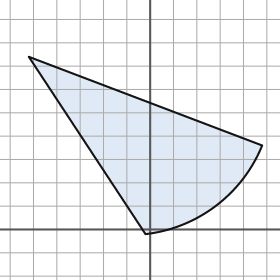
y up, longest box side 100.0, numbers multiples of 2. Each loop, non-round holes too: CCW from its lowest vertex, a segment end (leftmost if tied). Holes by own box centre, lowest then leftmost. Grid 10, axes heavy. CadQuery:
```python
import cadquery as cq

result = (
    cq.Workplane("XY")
    .moveTo(-2.0, -2.0)
    .threePointArc((28.0, 10.0), (48.0, 36.0))
    .lineTo(-52.0, 74.0)
    .close()
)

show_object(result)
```